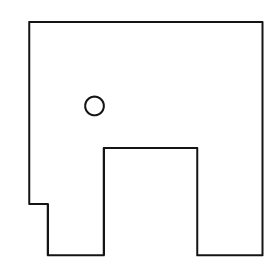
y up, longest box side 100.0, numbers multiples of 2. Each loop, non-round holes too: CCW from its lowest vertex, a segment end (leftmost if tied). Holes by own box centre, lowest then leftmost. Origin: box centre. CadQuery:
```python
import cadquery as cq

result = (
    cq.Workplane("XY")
    .moveTo(-42.0, -50.0)
    .lineTo(-18.0, -50.0)
    .lineTo(-18.0, -4.0)
    .lineTo(22.0, -4.0)
    .lineTo(22.0, -50.0)
    .lineTo(50.0, -50.0)
    .lineTo(50.0, 50.0)
    .lineTo(-50.0, 50.0)
    .lineTo(-50.0, -28.0)
    .lineTo(-42.0, -28.0)
    .close()
    .moveTo(-22.0, 14.0)
    .circle(4.0)
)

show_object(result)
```